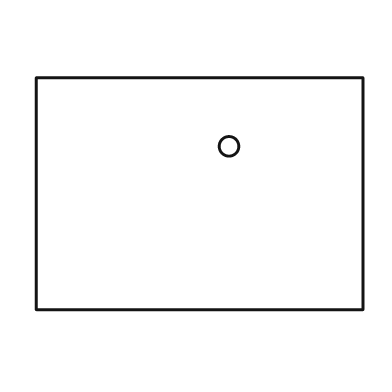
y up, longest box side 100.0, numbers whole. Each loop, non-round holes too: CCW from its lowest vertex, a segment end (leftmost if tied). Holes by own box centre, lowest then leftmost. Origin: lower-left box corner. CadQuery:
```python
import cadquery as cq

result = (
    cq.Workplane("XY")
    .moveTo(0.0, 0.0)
    .lineTo(100.0, 0.0)
    .lineTo(100.0, 71.0)
    .lineTo(0.0, 71.0)
    .close()
    .moveTo(59.0, 50.0)
    .circle(3.0)
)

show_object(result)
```